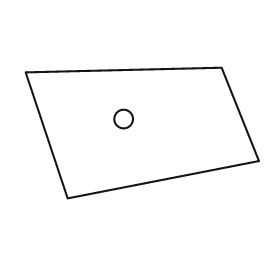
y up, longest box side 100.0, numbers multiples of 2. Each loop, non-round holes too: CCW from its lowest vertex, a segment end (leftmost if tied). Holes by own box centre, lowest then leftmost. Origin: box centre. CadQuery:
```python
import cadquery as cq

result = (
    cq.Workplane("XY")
    .moveTo(-32.0, -28.0)
    .lineTo(50.0, -12.0)
    .lineTo(34.0, 28.0)
    .lineTo(-50.0, 26.0)
    .close()
    .moveTo(-8.0, 6.0)
    .circle(4.0)
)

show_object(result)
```